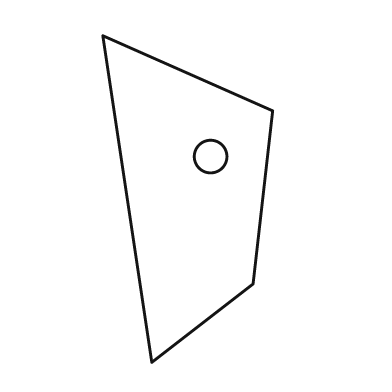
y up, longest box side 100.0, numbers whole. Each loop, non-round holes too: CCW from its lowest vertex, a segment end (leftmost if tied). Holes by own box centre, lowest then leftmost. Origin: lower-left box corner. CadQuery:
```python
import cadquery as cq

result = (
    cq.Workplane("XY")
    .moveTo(15.0, 0.0)
    .lineTo(46.0, 24.0)
    .lineTo(52.0, 77.0)
    .lineTo(0.0, 100.0)
    .close()
    .moveTo(33.0, 63.0)
    .circle(5.0)
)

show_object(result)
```